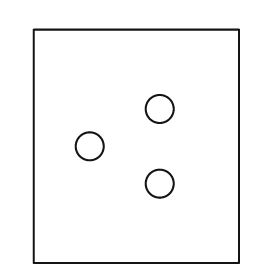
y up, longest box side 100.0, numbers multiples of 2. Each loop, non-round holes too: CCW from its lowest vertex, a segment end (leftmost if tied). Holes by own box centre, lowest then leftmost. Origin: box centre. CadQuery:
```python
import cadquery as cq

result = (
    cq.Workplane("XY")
    .moveTo(-44.0, -50.0)
    .lineTo(44.0, -50.0)
    .lineTo(44.0, 50.0)
    .lineTo(-44.0, 50.0)
    .close()
    .moveTo(10.0, -16.0)
    .circle(6.0)
    .moveTo(-20.0, 0.0)
    .circle(6.0)
    .moveTo(10.0, 16.0)
    .circle(6.0)
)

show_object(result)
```